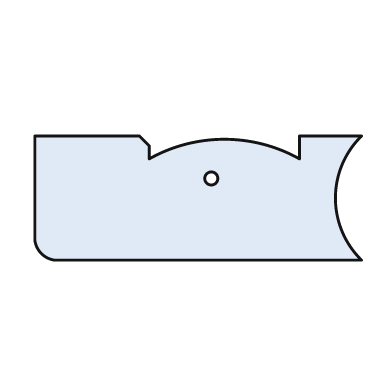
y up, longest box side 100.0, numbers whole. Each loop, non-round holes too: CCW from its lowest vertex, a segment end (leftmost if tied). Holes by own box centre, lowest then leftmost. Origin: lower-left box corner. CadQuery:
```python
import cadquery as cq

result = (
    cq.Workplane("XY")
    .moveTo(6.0, 0.0)
    .lineTo(100.0, 0.0)
    .threePointArc((92.0, 19.0), (100.0, 38.0))
    .lineTo(81.0, 38.0)
    .lineTo(81.0, 31.0)
    .threePointArc((58.0, 37.0), (35.0, 31.0))
    .lineTo(35.0, 35.0)
    .lineTo(32.0, 38.0)
    .lineTo(0.0, 38.0)
    .lineTo(0.0, 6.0)
    .threePointArc((2.0, 2.0), (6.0, 0.0))
    .close()
    .moveTo(54.0, 25.0)
    .circle(2.0)
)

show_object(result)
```